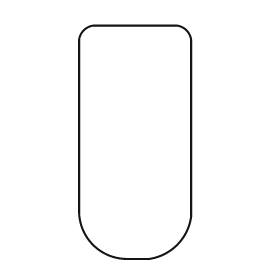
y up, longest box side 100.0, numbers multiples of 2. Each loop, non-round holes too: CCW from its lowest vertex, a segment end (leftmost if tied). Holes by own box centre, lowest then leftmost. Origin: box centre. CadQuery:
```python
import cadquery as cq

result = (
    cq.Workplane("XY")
    .moveTo(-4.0, -50.0)
    .lineTo(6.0, -50.0)
    .threePointArc((18.0, -44.0), (24.0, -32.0))
    .lineTo(24.0, 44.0)
    .threePointArc((22.0, 48.0), (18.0, 50.0))
    .lineTo(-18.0, 50.0)
    .threePointArc((-22.0, 48.0), (-24.0, 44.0))
    .lineTo(-24.0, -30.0)
    .threePointArc((-18.0, -44.0), (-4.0, -50.0))
    .close()
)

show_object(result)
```